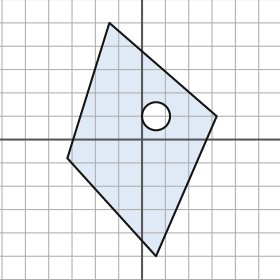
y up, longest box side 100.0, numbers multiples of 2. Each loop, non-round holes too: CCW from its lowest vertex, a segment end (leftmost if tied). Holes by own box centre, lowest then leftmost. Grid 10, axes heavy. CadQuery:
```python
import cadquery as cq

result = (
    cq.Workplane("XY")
    .moveTo(6.0, -50.0)
    .lineTo(32.0, 10.0)
    .lineTo(-14.0, 50.0)
    .lineTo(-32.0, -8.0)
    .close()
    .moveTo(6.0, 10.0)
    .circle(6.0)
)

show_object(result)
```